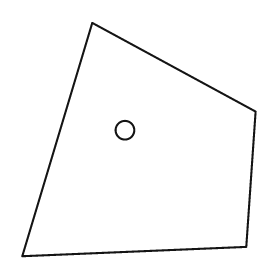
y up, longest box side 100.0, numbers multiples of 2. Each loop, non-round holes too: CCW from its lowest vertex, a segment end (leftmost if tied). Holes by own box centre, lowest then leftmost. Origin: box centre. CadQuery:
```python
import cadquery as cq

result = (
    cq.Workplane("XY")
    .moveTo(-50.0, -50.0)
    .lineTo(46.0, -46.0)
    .lineTo(50.0, 12.0)
    .lineTo(-20.0, 50.0)
    .close()
    .moveTo(-6.0, 4.0)
    .circle(4.0)
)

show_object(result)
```